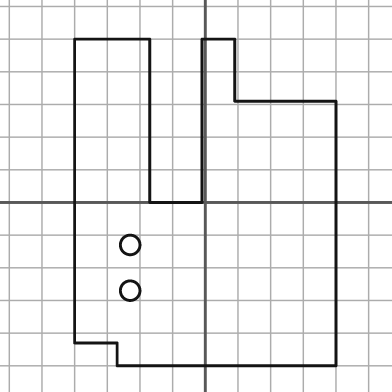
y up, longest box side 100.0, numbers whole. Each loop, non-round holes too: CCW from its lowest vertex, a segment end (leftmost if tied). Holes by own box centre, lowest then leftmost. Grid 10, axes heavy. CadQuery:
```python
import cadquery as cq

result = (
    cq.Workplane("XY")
    .moveTo(-27.0, -50.0)
    .lineTo(40.0, -50.0)
    .lineTo(40.0, 31.0)
    .lineTo(9.0, 31.0)
    .lineTo(9.0, 50.0)
    .lineTo(-1.0, 50.0)
    .lineTo(-1.0, 0.0)
    .lineTo(-17.0, 0.0)
    .lineTo(-17.0, 50.0)
    .lineTo(-40.0, 50.0)
    .lineTo(-40.0, -43.0)
    .lineTo(-27.0, -43.0)
    .close()
    .moveTo(-23.0, -27.0)
    .circle(3.0)
    .moveTo(-23.0, -13.0)
    .circle(3.0)
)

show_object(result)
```